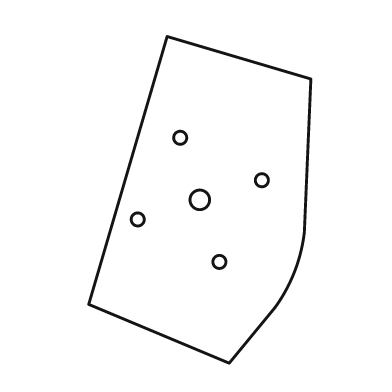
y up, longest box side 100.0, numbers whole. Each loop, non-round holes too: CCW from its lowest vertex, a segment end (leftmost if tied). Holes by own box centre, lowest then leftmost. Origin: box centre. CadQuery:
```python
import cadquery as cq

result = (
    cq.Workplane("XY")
    .moveTo(9.0, -50.0)
    .lineTo(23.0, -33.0)
    .threePointArc((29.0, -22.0), (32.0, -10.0))
    .lineTo(34.0, 37.0)
    .lineTo(-10.0, 50.0)
    .lineTo(-34.0, -32.0)
    .close()
    .moveTo(6.0, -19.0)
    .circle(2.0)
    .moveTo(-19.0, -6.0)
    .circle(2.0)
    .moveTo(0.0, 0.0)
    .circle(3.0)
    .moveTo(19.0, 6.0)
    .circle(2.0)
    .moveTo(-6.0, 19.0)
    .circle(2.0)
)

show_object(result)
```